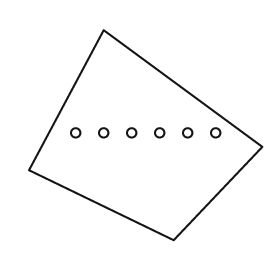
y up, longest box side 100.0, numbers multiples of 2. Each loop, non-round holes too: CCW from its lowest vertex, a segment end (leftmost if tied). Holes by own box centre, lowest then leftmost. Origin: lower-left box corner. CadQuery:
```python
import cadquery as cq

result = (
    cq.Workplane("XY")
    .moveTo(62.0, 0.0)
    .lineTo(100.0, 40.0)
    .lineTo(32.0, 90.0)
    .lineTo(0.0, 30.0)
    .close()
    .moveTo(20.0, 46.0)
    .circle(2.0)
    .moveTo(32.0, 46.0)
    .circle(2.0)
    .moveTo(44.0, 46.0)
    .circle(2.0)
    .moveTo(56.0, 46.0)
    .circle(2.0)
    .moveTo(68.0, 46.0)
    .circle(2.0)
    .moveTo(80.0, 46.0)
    .circle(2.0)
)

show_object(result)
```